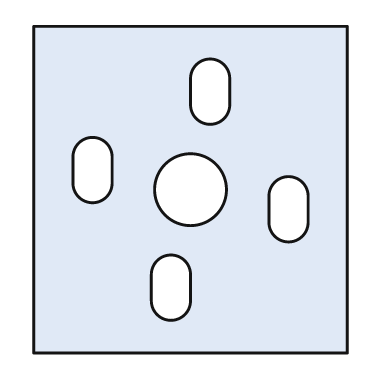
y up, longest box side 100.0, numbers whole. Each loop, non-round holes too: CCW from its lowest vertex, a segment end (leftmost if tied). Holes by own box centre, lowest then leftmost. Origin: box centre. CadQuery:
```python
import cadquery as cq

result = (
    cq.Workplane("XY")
    .moveTo(-48.0, -50.0)
    .lineTo(48.0, -50.0)
    .lineTo(48.0, 50.0)
    .lineTo(-48.0, 50.0)
    .close()
    .moveTo(-12.0, -34.0)
    .threePointArc((-6.0, -40.0), (0.0, -34.0))
    .lineTo(0.0, -26.0)
    .threePointArc((-6.0, -20.0), (-12.0, -26.0))
    .close()
    .moveTo(24.0, -10.0)
    .threePointArc((30.0, -16.0), (36.0, -10.0))
    .lineTo(36.0, -2.0)
    .threePointArc((30.0, 4.0), (24.0, -2.0))
    .close()
    .moveTo(0.0, 0.0)
    .circle(11.0)
    .moveTo(-36.0, 2.0)
    .threePointArc((-30.0, -4.0), (-24.0, 2.0))
    .lineTo(-24.0, 10.0)
    .threePointArc((-30.0, 16.0), (-36.0, 10.0))
    .close()
    .moveTo(0.0, 26.0)
    .threePointArc((6.0, 20.0), (12.0, 26.0))
    .lineTo(12.0, 34.0)
    .threePointArc((6.0, 40.0), (0.0, 34.0))
    .close()
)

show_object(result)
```